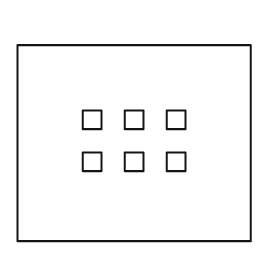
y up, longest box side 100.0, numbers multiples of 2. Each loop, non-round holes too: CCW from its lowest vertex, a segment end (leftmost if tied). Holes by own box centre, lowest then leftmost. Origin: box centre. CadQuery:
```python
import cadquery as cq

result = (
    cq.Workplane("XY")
    .moveTo(-50.0, -42.0)
    .lineTo(50.0, -42.0)
    .lineTo(50.0, 42.0)
    .lineTo(-50.0, 42.0)
    .close()
    .moveTo(-22.0, -12.0)
    .lineTo(-14.0, -12.0)
    .lineTo(-14.0, -4.0)
    .lineTo(-22.0, -4.0)
    .close()
    .moveTo(-4.0, -12.0)
    .lineTo(4.0, -12.0)
    .lineTo(4.0, -4.0)
    .lineTo(-4.0, -4.0)
    .close()
    .moveTo(14.0, -12.0)
    .lineTo(22.0, -12.0)
    .lineTo(22.0, -4.0)
    .lineTo(14.0, -4.0)
    .close()
    .moveTo(-22.0, 6.0)
    .lineTo(-14.0, 6.0)
    .lineTo(-14.0, 14.0)
    .lineTo(-22.0, 14.0)
    .close()
    .moveTo(-4.0, 6.0)
    .lineTo(4.0, 6.0)
    .lineTo(4.0, 14.0)
    .lineTo(-4.0, 14.0)
    .close()
    .moveTo(14.0, 6.0)
    .lineTo(22.0, 6.0)
    .lineTo(22.0, 14.0)
    .lineTo(14.0, 14.0)
    .close()
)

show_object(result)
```